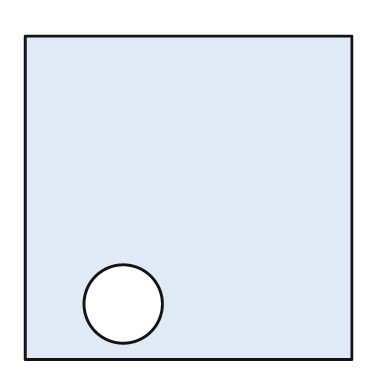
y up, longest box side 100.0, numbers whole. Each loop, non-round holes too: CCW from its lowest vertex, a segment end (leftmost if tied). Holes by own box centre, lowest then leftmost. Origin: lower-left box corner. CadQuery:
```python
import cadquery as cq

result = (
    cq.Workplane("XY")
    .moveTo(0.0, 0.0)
    .lineTo(100.0, 0.0)
    .lineTo(100.0, 99.0)
    .lineTo(0.0, 99.0)
    .close()
    .moveTo(30.0, 17.0)
    .circle(12.0)
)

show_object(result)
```